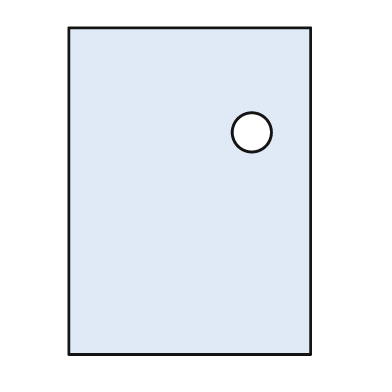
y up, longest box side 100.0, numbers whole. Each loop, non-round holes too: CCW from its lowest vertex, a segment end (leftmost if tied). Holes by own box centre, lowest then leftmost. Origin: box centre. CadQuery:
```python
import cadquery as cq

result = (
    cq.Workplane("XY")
    .moveTo(-37.0, -50.0)
    .lineTo(37.0, -50.0)
    .lineTo(37.0, 50.0)
    .lineTo(-37.0, 50.0)
    .close()
    .moveTo(19.0, 18.0)
    .circle(6.0)
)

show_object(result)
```